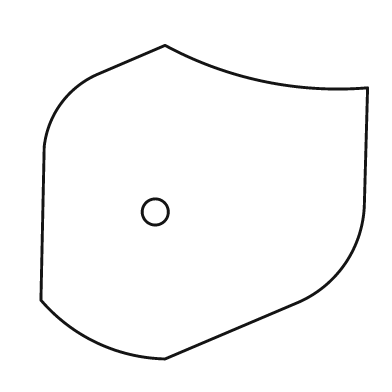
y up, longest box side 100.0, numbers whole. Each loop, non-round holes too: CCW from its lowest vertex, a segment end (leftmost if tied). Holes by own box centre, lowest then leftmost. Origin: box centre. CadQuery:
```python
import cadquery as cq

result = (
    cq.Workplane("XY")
    .moveTo(-12.0, -48.0)
    .lineTo(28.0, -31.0)
    .threePointArc((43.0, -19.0), (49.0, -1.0))
    .lineTo(50.0, 35.0)
    .threePointArc((18.0, 37.0), (-12.0, 48.0))
    .lineTo(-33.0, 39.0)
    .threePointArc((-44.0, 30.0), (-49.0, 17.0))
    .lineTo(-50.0, -30.0)
    .threePointArc((-33.0, -43.0), (-12.0, -48.0))
    .close()
    .moveTo(-15.0, -3.0)
    .circle(4.0)
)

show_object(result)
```